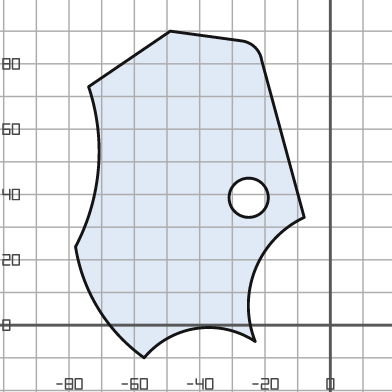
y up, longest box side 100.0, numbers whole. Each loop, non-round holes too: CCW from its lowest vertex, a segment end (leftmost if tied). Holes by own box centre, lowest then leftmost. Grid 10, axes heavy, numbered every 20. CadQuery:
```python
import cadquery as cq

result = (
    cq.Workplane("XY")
    .moveTo(-57.0, -10.0)
    .threePointArc((-41.0, -1.0), (-23.0, -5.0))
    .threePointArc((-23.0, 17.0), (-8.0, 33.0))
    .lineTo(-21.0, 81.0)
    .threePointArc((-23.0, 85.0), (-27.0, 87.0))
    .lineTo(-49.0, 90.0)
    .lineTo(-74.0, 73.0)
    .threePointArc((-71.0, 48.0), (-78.0, 24.0))
    .threePointArc((-71.0, 5.0), (-57.0, -10.0))
    .close()
    .moveTo(-25.0, 39.0)
    .circle(6.0)
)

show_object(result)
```